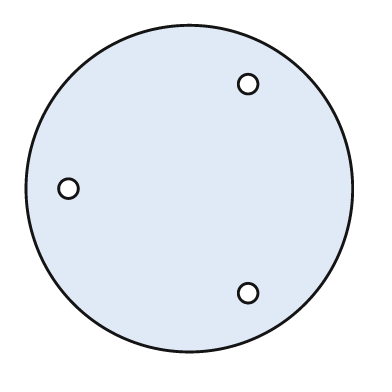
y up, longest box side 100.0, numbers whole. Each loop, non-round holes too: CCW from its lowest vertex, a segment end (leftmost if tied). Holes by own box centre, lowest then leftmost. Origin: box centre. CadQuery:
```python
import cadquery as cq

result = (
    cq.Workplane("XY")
    .moveTo(0.0, 0.0)
    .circle(50.0)
    .moveTo(18.0, -32.0)
    .circle(3.0)
    .moveTo(-37.0, 0.0)
    .circle(3.0)
    .moveTo(18.0, 32.0)
    .circle(3.0)
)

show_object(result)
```